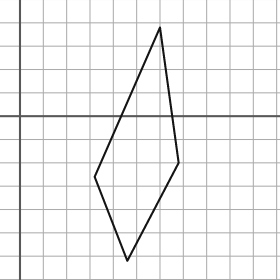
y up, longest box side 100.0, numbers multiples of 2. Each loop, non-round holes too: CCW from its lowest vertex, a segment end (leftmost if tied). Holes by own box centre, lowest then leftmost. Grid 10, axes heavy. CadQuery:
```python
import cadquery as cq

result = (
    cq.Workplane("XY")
    .moveTo(46.0, -62.0)
    .lineTo(68.0, -20.0)
    .lineTo(60.0, 38.0)
    .lineTo(32.0, -26.0)
    .close()
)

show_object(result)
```